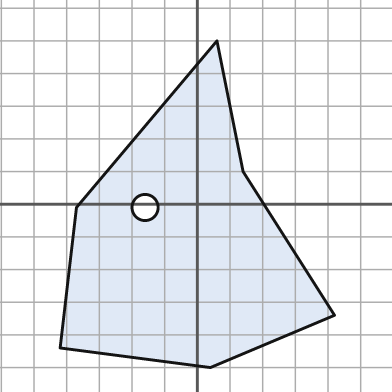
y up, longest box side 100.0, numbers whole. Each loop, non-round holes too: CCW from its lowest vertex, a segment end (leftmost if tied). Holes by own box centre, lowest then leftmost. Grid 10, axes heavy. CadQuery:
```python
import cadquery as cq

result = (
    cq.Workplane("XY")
    .moveTo(4.0, -50.0)
    .lineTo(42.0, -34.0)
    .lineTo(14.0, 10.0)
    .lineTo(6.0, 50.0)
    .lineTo(-37.0, -1.0)
    .lineTo(-42.0, -44.0)
    .close()
    .moveTo(-16.0, -1.0)
    .circle(4.0)
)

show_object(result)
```